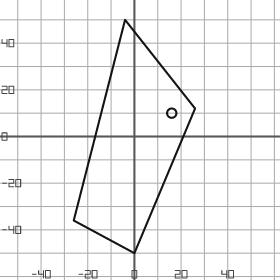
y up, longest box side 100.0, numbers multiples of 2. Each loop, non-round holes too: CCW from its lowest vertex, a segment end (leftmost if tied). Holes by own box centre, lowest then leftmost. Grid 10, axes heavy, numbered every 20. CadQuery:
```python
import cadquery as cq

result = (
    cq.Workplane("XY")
    .moveTo(0.0, -50.0)
    .lineTo(26.0, 12.0)
    .lineTo(-4.0, 50.0)
    .lineTo(-26.0, -36.0)
    .close()
    .moveTo(16.0, 10.0)
    .circle(2.0)
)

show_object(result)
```